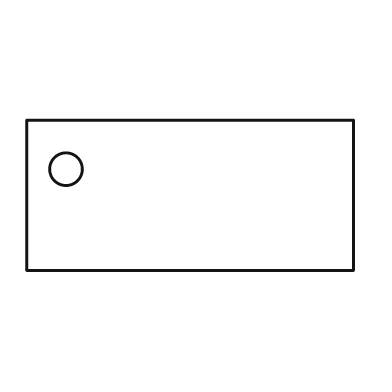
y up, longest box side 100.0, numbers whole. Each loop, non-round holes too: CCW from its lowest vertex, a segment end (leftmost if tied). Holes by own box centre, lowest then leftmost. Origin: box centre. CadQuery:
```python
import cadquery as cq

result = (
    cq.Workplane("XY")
    .moveTo(-50.0, -23.0)
    .lineTo(50.0, -23.0)
    .lineTo(50.0, 23.0)
    .lineTo(-50.0, 23.0)
    .close()
    .moveTo(-38.0, 8.0)
    .circle(5.0)
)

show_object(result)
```